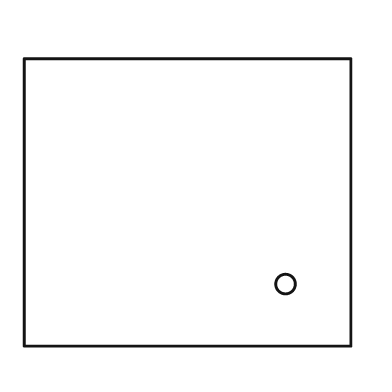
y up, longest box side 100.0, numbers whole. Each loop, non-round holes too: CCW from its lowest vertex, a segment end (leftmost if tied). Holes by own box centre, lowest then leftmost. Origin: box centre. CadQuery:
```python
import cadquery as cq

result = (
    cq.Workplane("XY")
    .moveTo(-50.0, -44.0)
    .lineTo(50.0, -44.0)
    .lineTo(50.0, 44.0)
    .lineTo(-50.0, 44.0)
    .close()
    .moveTo(30.0, -25.0)
    .circle(3.0)
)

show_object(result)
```